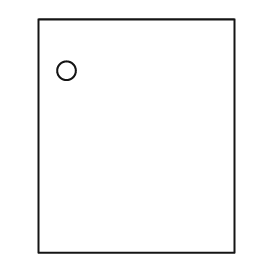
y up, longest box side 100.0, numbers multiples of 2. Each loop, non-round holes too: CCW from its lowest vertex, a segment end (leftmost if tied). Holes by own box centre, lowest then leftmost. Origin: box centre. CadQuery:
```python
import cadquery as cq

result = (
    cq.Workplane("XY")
    .moveTo(-42.0, -50.0)
    .lineTo(42.0, -50.0)
    .lineTo(42.0, 50.0)
    .lineTo(-42.0, 50.0)
    .close()
    .moveTo(-30.0, 28.0)
    .circle(4.0)
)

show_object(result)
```